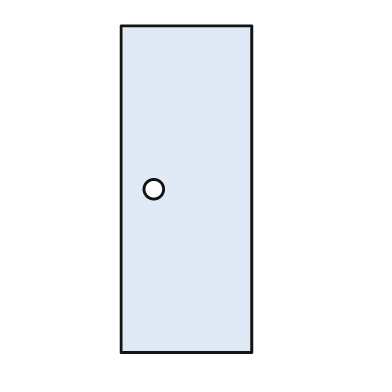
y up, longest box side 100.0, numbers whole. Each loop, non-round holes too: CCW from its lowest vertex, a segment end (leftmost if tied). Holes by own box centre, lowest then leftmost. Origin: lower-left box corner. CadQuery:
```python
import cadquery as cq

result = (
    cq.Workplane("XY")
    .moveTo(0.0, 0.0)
    .lineTo(40.0, 0.0)
    .lineTo(40.0, 100.0)
    .lineTo(0.0, 100.0)
    .close()
    .moveTo(10.0, 50.0)
    .circle(3.0)
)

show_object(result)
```